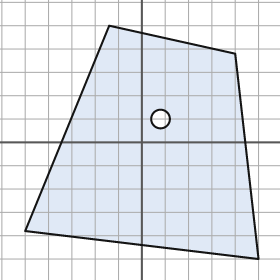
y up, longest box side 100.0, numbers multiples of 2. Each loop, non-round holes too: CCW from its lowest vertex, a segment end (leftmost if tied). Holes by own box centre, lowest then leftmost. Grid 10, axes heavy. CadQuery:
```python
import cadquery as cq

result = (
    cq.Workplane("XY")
    .moveTo(50.0, -50.0)
    .lineTo(40.0, 38.0)
    .lineTo(-14.0, 50.0)
    .lineTo(-50.0, -38.0)
    .close()
    .moveTo(8.0, 10.0)
    .circle(4.0)
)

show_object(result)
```